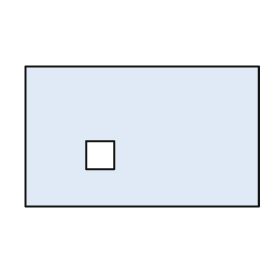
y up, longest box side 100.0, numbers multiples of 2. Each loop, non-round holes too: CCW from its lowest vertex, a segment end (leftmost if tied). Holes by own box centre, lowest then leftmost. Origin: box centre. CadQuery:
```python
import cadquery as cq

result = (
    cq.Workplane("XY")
    .moveTo(-50.0, -30.0)
    .lineTo(50.0, -30.0)
    .lineTo(50.0, 30.0)
    .lineTo(-50.0, 30.0)
    .close()
    .moveTo(-24.0, -14.0)
    .lineTo(-12.0, -14.0)
    .lineTo(-12.0, -2.0)
    .lineTo(-24.0, -2.0)
    .close()
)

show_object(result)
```